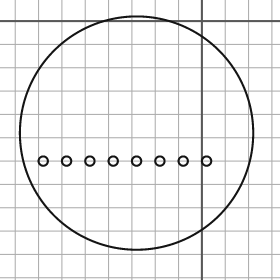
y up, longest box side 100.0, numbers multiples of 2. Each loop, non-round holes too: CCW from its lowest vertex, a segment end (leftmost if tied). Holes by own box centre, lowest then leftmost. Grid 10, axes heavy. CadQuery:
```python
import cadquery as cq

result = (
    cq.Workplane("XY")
    .moveTo(-28.0, -48.0)
    .circle(50.0)
    .moveTo(-68.0, -60.0)
    .circle(2.0)
    .moveTo(-58.0, -60.0)
    .circle(2.0)
    .moveTo(-48.0, -60.0)
    .circle(2.0)
    .moveTo(-38.0, -60.0)
    .circle(2.0)
    .moveTo(-28.0, -60.0)
    .circle(2.0)
    .moveTo(-18.0, -60.0)
    .circle(2.0)
    .moveTo(-8.0, -60.0)
    .circle(2.0)
    .moveTo(2.0, -60.0)
    .circle(2.0)
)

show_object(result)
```